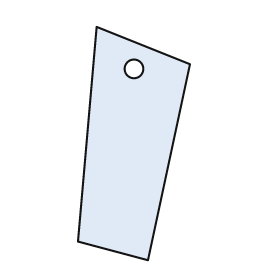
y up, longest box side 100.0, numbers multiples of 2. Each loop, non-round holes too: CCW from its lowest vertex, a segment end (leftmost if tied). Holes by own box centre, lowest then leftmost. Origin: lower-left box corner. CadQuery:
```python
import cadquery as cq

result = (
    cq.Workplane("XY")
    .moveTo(30.0, 0.0)
    .lineTo(48.0, 84.0)
    .lineTo(8.0, 100.0)
    .lineTo(0.0, 8.0)
    .close()
    .moveTo(24.0, 82.0)
    .circle(4.0)
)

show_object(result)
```